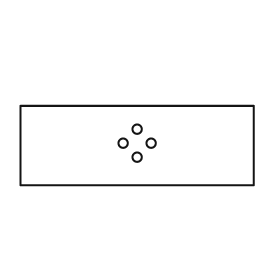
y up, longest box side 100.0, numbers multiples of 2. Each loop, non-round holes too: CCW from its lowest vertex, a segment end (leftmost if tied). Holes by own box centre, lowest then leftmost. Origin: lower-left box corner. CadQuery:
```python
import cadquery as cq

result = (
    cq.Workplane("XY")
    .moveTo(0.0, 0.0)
    .lineTo(100.0, 0.0)
    .lineTo(100.0, 34.0)
    .lineTo(0.0, 34.0)
    .close()
    .moveTo(50.0, 12.0)
    .circle(2.0)
    .moveTo(44.0, 18.0)
    .circle(2.0)
    .moveTo(56.0, 18.0)
    .circle(2.0)
    .moveTo(50.0, 24.0)
    .circle(2.0)
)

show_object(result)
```